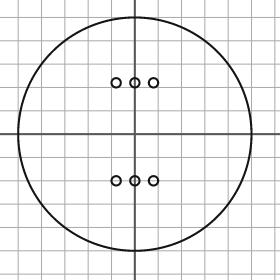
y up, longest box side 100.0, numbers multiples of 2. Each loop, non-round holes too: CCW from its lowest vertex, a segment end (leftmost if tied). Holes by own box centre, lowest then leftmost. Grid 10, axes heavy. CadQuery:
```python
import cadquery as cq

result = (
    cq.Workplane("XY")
    .moveTo(0.0, 0.0)
    .circle(50.0)
    .moveTo(-8.0, -20.0)
    .circle(2.0)
    .moveTo(0.0, -20.0)
    .circle(2.0)
    .moveTo(8.0, -20.0)
    .circle(2.0)
    .moveTo(-8.0, 22.0)
    .circle(2.0)
    .moveTo(0.0, 22.0)
    .circle(2.0)
    .moveTo(8.0, 22.0)
    .circle(2.0)
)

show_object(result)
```